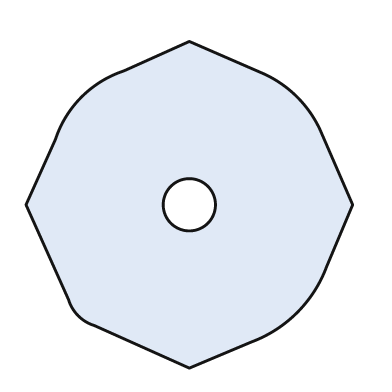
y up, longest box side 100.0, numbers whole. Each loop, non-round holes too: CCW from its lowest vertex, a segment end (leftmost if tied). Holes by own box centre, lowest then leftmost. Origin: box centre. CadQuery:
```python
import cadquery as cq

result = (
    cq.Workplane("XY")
    .moveTo(0.0, -50.0)
    .lineTo(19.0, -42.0)
    .threePointArc((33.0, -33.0), (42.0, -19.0))
    .lineTo(50.0, 0.0)
    .lineTo(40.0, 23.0)
    .threePointArc((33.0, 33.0), (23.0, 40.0))
    .lineTo(0.0, 50.0)
    .lineTo(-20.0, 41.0)
    .threePointArc((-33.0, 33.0), (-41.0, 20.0))
    .lineTo(-50.0, 0.0)
    .lineTo(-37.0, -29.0)
    .threePointArc((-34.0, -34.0), (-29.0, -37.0))
    .close()
    .moveTo(0.0, 0.0)
    .circle(8.0)
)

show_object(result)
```